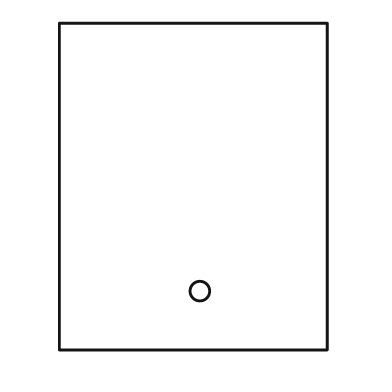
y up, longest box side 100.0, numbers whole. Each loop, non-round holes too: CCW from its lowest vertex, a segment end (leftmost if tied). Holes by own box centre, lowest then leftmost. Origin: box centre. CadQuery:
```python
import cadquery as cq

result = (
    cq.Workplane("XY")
    .moveTo(-41.0, -50.0)
    .lineTo(41.0, -50.0)
    .lineTo(41.0, 50.0)
    .lineTo(-41.0, 50.0)
    .close()
    .moveTo(2.0, -32.0)
    .circle(3.0)
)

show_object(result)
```